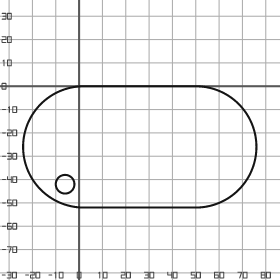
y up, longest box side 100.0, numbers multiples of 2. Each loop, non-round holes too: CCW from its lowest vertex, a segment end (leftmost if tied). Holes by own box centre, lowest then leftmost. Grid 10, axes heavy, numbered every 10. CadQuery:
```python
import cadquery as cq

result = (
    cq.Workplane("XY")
    .moveTo(2.0, -52.0)
    .lineTo(50.0, -52.0)
    .threePointArc((76.0, -26.0), (50.0, 0.0))
    .lineTo(2.0, 0.0)
    .threePointArc((-24.0, -26.0), (2.0, -52.0))
    .close()
    .moveTo(-6.0, -42.0)
    .circle(4.0)
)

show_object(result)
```